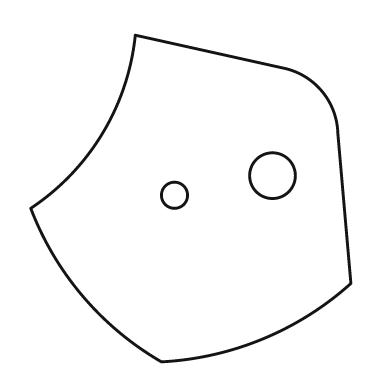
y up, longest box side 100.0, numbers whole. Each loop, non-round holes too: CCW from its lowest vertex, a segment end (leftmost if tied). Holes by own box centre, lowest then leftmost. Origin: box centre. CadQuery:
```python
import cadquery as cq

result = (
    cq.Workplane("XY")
    .moveTo(-9.0, -50.0)
    .threePointArc((22.0, -43.0), (49.0, -26.0))
    .lineTo(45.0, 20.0)
    .threePointArc((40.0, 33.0), (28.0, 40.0))
    .lineTo(-17.0, 50.0)
    .threePointArc((-27.0, 20.0), (-49.0, -3.0))
    .threePointArc((-33.0, -30.0), (-9.0, -50.0))
    .close()
    .moveTo(-5.0, 1.0)
    .circle(4.0)
    .moveTo(25.0, 7.0)
    .circle(7.0)
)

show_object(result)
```